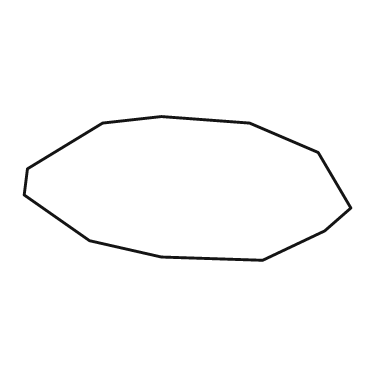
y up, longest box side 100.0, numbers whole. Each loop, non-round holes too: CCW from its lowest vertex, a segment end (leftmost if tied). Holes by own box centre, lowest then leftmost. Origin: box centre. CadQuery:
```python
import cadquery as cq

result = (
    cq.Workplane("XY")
    .moveTo(23.0, -22.0)
    .lineTo(42.0, -13.0)
    .lineTo(50.0, -6.0)
    .lineTo(40.0, 11.0)
    .lineTo(19.0, 20.0)
    .lineTo(-8.0, 22.0)
    .lineTo(-26.0, 20.0)
    .lineTo(-49.0, 6.0)
    .lineTo(-50.0, -2.0)
    .lineTo(-30.0, -16.0)
    .lineTo(-8.0, -21.0)
    .close()
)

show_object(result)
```